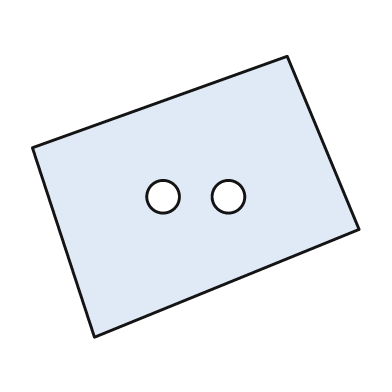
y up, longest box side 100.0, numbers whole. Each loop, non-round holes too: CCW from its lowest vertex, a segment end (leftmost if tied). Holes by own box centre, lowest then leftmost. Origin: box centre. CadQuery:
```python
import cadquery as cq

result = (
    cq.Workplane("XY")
    .moveTo(-31.0, -43.0)
    .lineTo(50.0, -10.0)
    .lineTo(28.0, 43.0)
    .lineTo(-50.0, 15.0)
    .close()
    .moveTo(-10.0, 0.0)
    .circle(5.0)
    .moveTo(10.0, 0.0)
    .circle(5.0)
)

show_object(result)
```